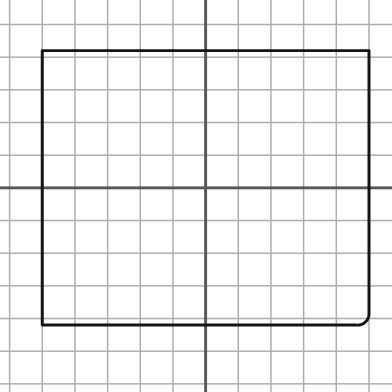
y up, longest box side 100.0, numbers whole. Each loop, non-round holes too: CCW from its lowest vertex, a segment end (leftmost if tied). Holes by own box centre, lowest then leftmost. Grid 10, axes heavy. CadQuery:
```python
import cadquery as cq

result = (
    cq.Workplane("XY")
    .moveTo(-50.0, -42.0)
    .lineTo(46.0, -42.0)
    .threePointArc((49.0, -41.0), (50.0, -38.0))
    .lineTo(50.0, 42.0)
    .lineTo(-50.0, 42.0)
    .close()
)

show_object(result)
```